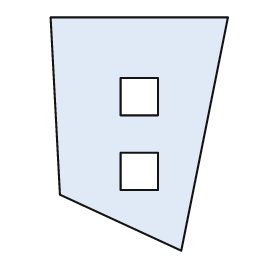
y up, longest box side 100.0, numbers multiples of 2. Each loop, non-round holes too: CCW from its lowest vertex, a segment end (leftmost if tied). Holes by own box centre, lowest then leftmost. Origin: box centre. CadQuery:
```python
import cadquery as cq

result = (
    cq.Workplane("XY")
    .moveTo(18.0, -50.0)
    .lineTo(38.0, 50.0)
    .lineTo(-38.0, 50.0)
    .lineTo(-34.0, -26.0)
    .close()
    .moveTo(-8.0, -24.0)
    .lineTo(8.0, -24.0)
    .lineTo(8.0, -8.0)
    .lineTo(-8.0, -8.0)
    .close()
    .moveTo(-8.0, 8.0)
    .lineTo(8.0, 8.0)
    .lineTo(8.0, 24.0)
    .lineTo(-8.0, 24.0)
    .close()
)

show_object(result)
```